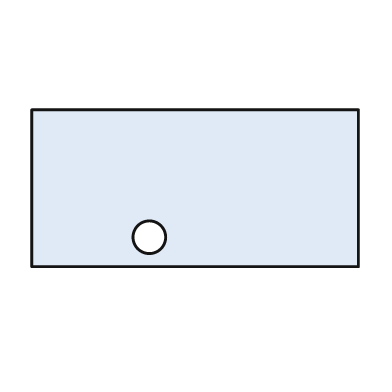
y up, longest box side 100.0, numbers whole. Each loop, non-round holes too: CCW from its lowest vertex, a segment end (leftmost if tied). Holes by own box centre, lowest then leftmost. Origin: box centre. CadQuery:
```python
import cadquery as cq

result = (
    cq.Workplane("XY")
    .moveTo(-50.0, -24.0)
    .lineTo(50.0, -24.0)
    .lineTo(50.0, 24.0)
    .lineTo(-50.0, 24.0)
    .close()
    .moveTo(-14.0, -15.0)
    .circle(5.0)
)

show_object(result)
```